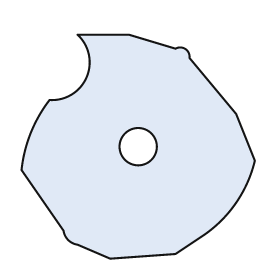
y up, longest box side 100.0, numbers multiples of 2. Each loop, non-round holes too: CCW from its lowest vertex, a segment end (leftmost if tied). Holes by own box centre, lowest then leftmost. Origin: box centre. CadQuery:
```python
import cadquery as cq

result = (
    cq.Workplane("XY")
    .moveTo(-12.0, -48.0)
    .lineTo(16.0, -46.0)
    .lineTo(28.0, -38.0)
    .threePointArc((42.0, -24.0), (50.0, -6.0))
    .lineTo(42.0, 14.0)
    .lineTo(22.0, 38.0)
    .threePointArc((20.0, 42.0), (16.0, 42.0))
    .lineTo(-4.0, 48.0)
    .lineTo(-26.0, 48.0)
    .threePointArc((-22.0, 30.0), (-38.0, 20.0))
    .threePointArc((-46.0, 6.0), (-50.0, -10.0))
    .lineTo(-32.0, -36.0)
    .threePointArc((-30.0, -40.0), (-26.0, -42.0))
    .close()
    .moveTo(0.0, 0.0)
    .circle(8.0)
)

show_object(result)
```